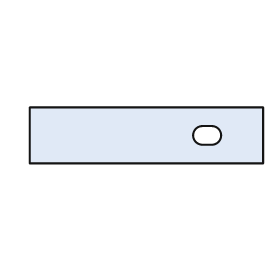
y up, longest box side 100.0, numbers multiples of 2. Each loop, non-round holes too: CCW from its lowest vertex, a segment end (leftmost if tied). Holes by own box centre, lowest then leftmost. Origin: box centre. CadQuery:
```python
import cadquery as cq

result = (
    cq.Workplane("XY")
    .moveTo(-50.0, -12.0)
    .lineTo(50.0, -12.0)
    .lineTo(50.0, 12.0)
    .lineTo(-50.0, 12.0)
    .close()
    .moveTo(24.0, -4.0)
    .lineTo(28.0, -4.0)
    .threePointArc((32.0, 0.0), (28.0, 4.0))
    .lineTo(24.0, 4.0)
    .threePointArc((20.0, 0.0), (24.0, -4.0))
    .close()
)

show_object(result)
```